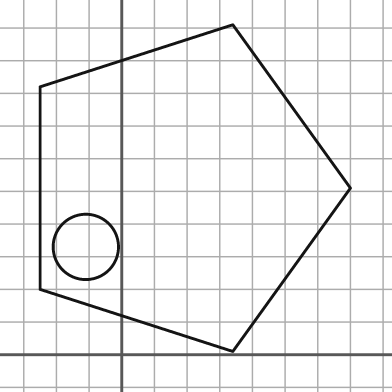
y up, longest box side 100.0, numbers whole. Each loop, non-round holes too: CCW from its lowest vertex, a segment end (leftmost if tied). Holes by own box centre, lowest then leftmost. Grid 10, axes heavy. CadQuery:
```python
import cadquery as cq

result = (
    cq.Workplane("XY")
    .moveTo(34.0, 1.0)
    .lineTo(70.0, 51.0)
    .lineTo(34.0, 101.0)
    .lineTo(-25.0, 82.0)
    .lineTo(-25.0, 20.0)
    .close()
    .moveTo(-11.0, 33.0)
    .circle(10.0)
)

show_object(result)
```